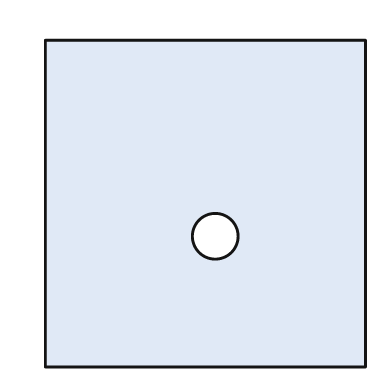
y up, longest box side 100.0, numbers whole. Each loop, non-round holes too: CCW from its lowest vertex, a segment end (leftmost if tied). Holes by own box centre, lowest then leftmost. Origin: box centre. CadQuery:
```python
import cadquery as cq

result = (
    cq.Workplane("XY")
    .moveTo(-49.0, -50.0)
    .lineTo(49.0, -50.0)
    .lineTo(49.0, 50.0)
    .lineTo(-49.0, 50.0)
    .close()
    .moveTo(3.0, -10.0)
    .circle(7.0)
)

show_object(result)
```